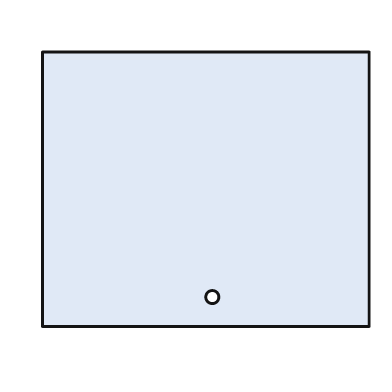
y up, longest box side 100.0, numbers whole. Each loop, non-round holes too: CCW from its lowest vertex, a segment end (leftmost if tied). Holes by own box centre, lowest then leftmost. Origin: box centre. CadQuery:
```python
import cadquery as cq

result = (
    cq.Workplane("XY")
    .moveTo(-50.0, -42.0)
    .lineTo(50.0, -42.0)
    .lineTo(50.0, 42.0)
    .lineTo(-50.0, 42.0)
    .close()
    .moveTo(2.0, -33.0)
    .circle(2.0)
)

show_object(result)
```